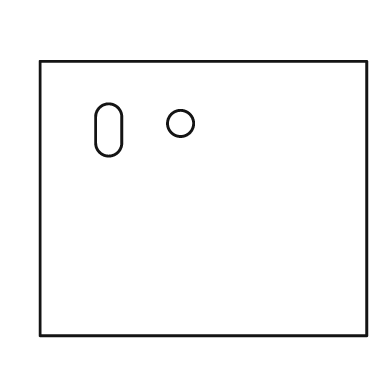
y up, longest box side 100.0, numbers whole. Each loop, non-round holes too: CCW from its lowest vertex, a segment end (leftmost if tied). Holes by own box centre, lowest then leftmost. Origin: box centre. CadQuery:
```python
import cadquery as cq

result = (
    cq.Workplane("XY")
    .moveTo(-50.0, -42.0)
    .lineTo(50.0, -42.0)
    .lineTo(50.0, 42.0)
    .lineTo(-50.0, 42.0)
    .close()
    .moveTo(-33.0, 17.0)
    .threePointArc((-29.0, 13.0), (-25.0, 17.0))
    .lineTo(-25.0, 25.0)
    .threePointArc((-29.0, 29.0), (-33.0, 25.0))
    .close()
    .moveTo(-7.0, 23.0)
    .circle(4.0)
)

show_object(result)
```